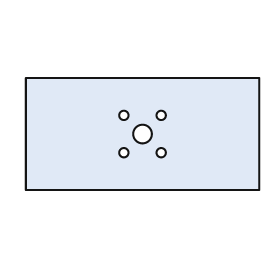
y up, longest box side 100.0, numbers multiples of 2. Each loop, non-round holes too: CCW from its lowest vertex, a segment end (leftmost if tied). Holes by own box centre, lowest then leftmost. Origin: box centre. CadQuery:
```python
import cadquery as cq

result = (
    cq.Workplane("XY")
    .moveTo(-50.0, -24.0)
    .lineTo(50.0, -24.0)
    .lineTo(50.0, 24.0)
    .lineTo(-50.0, 24.0)
    .close()
    .moveTo(-8.0, -8.0)
    .circle(2.0)
    .moveTo(8.0, -8.0)
    .circle(2.0)
    .moveTo(0.0, 0.0)
    .circle(4.0)
    .moveTo(-8.0, 8.0)
    .circle(2.0)
    .moveTo(8.0, 8.0)
    .circle(2.0)
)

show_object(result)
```